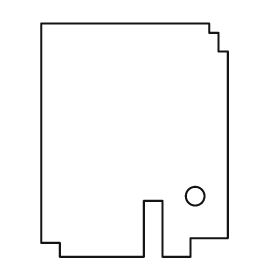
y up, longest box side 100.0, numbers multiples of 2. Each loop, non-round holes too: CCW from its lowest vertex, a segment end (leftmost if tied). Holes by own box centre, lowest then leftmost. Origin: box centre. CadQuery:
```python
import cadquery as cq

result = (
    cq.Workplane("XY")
    .moveTo(-32.0, -50.0)
    .lineTo(4.0, -50.0)
    .lineTo(4.0, -26.0)
    .lineTo(12.0, -26.0)
    .lineTo(12.0, -50.0)
    .lineTo(24.0, -50.0)
    .lineTo(24.0, -42.0)
    .lineTo(40.0, -42.0)
    .lineTo(40.0, 38.0)
    .lineTo(36.0, 38.0)
    .lineTo(36.0, 46.0)
    .lineTo(32.0, 46.0)
    .lineTo(32.0, 50.0)
    .lineTo(-40.0, 50.0)
    .lineTo(-40.0, -44.0)
    .lineTo(-32.0, -44.0)
    .close()
    .moveTo(26.0, -24.0)
    .circle(4.0)
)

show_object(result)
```